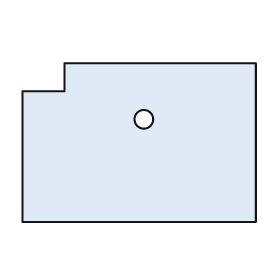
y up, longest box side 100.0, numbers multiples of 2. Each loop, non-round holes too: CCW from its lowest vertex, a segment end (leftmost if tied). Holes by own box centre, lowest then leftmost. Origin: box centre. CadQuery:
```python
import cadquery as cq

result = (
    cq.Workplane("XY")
    .moveTo(-50.0, -34.0)
    .lineTo(50.0, -34.0)
    .lineTo(50.0, 34.0)
    .lineTo(-32.0, 34.0)
    .lineTo(-32.0, 22.0)
    .lineTo(-50.0, 22.0)
    .close()
    .moveTo(2.0, 10.0)
    .circle(4.0)
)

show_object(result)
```